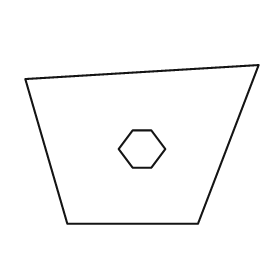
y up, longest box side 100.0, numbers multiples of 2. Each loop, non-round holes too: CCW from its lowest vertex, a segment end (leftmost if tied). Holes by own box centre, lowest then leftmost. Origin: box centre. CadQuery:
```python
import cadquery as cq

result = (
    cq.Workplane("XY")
    .moveTo(-32.0, -34.0)
    .lineTo(24.0, -34.0)
    .lineTo(50.0, 34.0)
    .lineTo(-50.0, 28.0)
    .close()
    .moveTo(-4.0, -10.0)
    .lineTo(4.0, -10.0)
    .lineTo(10.0, -2.0)
    .lineTo(4.0, 6.0)
    .lineTo(-4.0, 6.0)
    .lineTo(-10.0, -2.0)
    .close()
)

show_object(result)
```